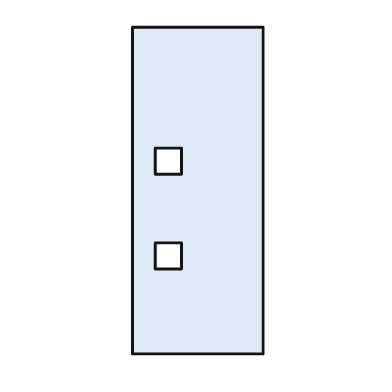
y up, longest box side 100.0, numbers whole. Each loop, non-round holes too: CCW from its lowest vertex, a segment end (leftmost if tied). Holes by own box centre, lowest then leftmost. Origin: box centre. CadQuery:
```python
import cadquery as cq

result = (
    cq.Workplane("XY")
    .moveTo(-20.0, -50.0)
    .lineTo(20.0, -50.0)
    .lineTo(20.0, 50.0)
    .lineTo(-20.0, 50.0)
    .close()
    .moveTo(-13.0, -24.0)
    .lineTo(-5.0, -24.0)
    .lineTo(-5.0, -16.0)
    .lineTo(-13.0, -16.0)
    .close()
    .moveTo(-13.0, 5.0)
    .lineTo(-5.0, 5.0)
    .lineTo(-5.0, 13.0)
    .lineTo(-13.0, 13.0)
    .close()
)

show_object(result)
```